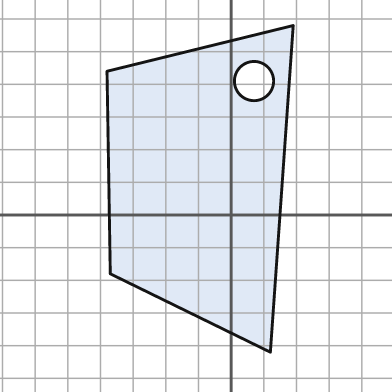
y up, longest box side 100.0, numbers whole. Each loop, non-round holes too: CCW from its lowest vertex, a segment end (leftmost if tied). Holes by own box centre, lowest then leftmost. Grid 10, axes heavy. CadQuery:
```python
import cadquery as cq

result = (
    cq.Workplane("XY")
    .moveTo(12.0, -42.0)
    .lineTo(19.0, 58.0)
    .lineTo(-38.0, 44.0)
    .lineTo(-37.0, -18.0)
    .close()
    .moveTo(7.0, 41.0)
    .circle(6.0)
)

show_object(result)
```